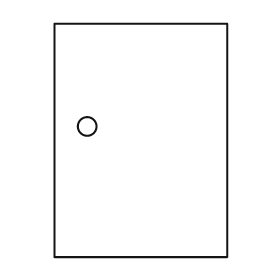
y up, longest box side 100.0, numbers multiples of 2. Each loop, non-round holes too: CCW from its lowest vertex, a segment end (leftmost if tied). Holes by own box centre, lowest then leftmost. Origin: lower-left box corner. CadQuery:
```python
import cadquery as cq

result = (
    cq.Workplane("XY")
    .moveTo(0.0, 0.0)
    .lineTo(74.0, 0.0)
    .lineTo(74.0, 100.0)
    .lineTo(0.0, 100.0)
    .close()
    .moveTo(14.0, 56.0)
    .circle(4.0)
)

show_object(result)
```